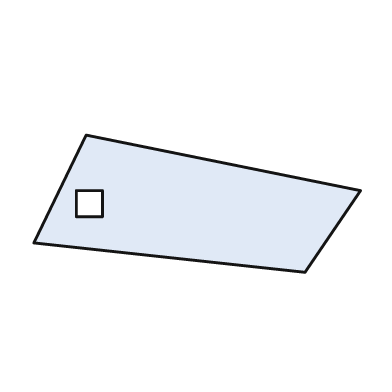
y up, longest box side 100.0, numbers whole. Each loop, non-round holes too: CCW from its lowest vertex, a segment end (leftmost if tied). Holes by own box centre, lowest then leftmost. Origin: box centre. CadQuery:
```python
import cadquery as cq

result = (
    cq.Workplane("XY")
    .moveTo(33.0, -21.0)
    .lineTo(50.0, 4.0)
    .lineTo(-34.0, 21.0)
    .lineTo(-50.0, -12.0)
    .close()
    .moveTo(-37.0, -4.0)
    .lineTo(-29.0, -4.0)
    .lineTo(-29.0, 4.0)
    .lineTo(-37.0, 4.0)
    .close()
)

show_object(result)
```